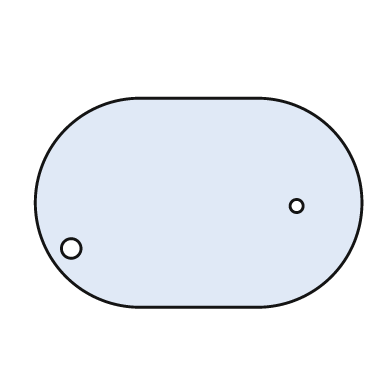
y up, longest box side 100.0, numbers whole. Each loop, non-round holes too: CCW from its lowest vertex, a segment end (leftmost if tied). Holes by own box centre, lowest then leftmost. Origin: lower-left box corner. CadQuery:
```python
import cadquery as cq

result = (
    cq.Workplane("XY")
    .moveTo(32.0, 0.0)
    .lineTo(68.0, 0.0)
    .threePointArc((100.0, 32.0), (68.0, 64.0))
    .lineTo(32.0, 64.0)
    .threePointArc((0.0, 32.0), (32.0, 0.0))
    .close()
    .moveTo(11.0, 18.0)
    .circle(3.0)
    .moveTo(80.0, 31.0)
    .circle(2.0)
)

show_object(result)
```